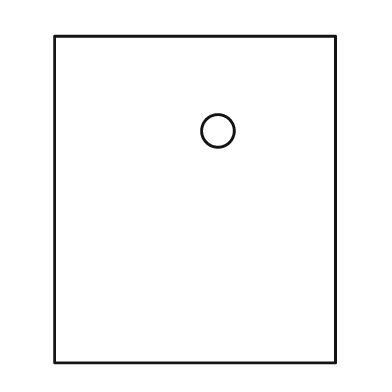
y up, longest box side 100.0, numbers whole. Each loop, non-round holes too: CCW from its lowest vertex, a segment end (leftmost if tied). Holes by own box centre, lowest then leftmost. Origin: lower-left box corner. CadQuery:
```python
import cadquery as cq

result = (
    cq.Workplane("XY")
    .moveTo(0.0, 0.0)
    .lineTo(86.0, 0.0)
    .lineTo(86.0, 100.0)
    .lineTo(0.0, 100.0)
    .close()
    .moveTo(50.0, 71.0)
    .circle(5.0)
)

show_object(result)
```